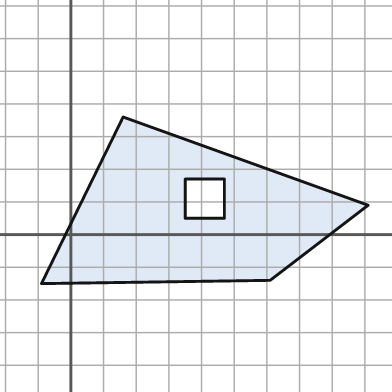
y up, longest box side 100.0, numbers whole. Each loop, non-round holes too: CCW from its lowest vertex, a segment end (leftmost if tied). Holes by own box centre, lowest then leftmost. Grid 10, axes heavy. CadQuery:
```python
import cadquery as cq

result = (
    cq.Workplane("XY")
    .moveTo(-9.0, -15.0)
    .lineTo(61.0, -14.0)
    .lineTo(91.0, 9.0)
    .lineTo(16.0, 36.0)
    .close()
    .moveTo(35.0, 5.0)
    .lineTo(47.0, 5.0)
    .lineTo(47.0, 17.0)
    .lineTo(35.0, 17.0)
    .close()
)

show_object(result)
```